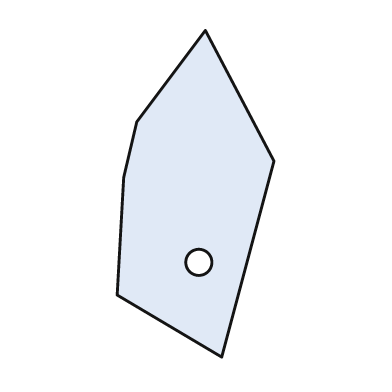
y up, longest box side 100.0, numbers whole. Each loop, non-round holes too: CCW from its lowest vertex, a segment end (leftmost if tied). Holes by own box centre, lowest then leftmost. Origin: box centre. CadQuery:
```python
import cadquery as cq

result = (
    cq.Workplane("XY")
    .moveTo(8.0, -50.0)
    .lineTo(24.0, 10.0)
    .lineTo(3.0, 50.0)
    .lineTo(-18.0, 22.0)
    .lineTo(-22.0, 5.0)
    .lineTo(-24.0, -31.0)
    .close()
    .moveTo(1.0, -21.0)
    .circle(4.0)
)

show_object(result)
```